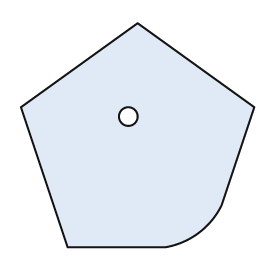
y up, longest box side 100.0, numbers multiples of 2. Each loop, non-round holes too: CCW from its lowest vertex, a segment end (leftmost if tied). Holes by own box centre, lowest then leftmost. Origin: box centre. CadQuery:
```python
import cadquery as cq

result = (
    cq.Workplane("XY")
    .moveTo(-30.0, -48.0)
    .lineTo(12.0, -48.0)
    .threePointArc((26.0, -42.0), (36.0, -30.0))
    .lineTo(50.0, 12.0)
    .lineTo(0.0, 48.0)
    .lineTo(-50.0, 12.0)
    .close()
    .moveTo(-4.0, 8.0)
    .circle(4.0)
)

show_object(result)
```